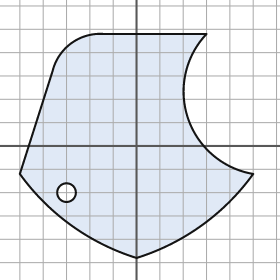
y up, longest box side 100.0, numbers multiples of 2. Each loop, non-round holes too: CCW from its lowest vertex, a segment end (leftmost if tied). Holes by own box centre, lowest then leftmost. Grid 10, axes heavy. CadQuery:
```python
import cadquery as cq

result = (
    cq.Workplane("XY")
    .moveTo(0.0, -48.0)
    .threePointArc((28.0, -34.0), (50.0, -12.0))
    .threePointArc((22.0, 12.0), (30.0, 48.0))
    .lineTo(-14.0, 48.0)
    .threePointArc((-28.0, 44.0), (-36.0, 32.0))
    .lineTo(-50.0, -12.0)
    .threePointArc((-28.0, -34.0), (0.0, -48.0))
    .close()
    .moveTo(-30.0, -20.0)
    .circle(4.0)
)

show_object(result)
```